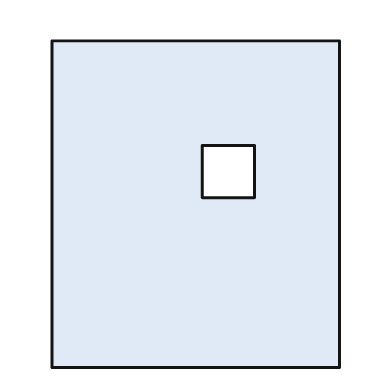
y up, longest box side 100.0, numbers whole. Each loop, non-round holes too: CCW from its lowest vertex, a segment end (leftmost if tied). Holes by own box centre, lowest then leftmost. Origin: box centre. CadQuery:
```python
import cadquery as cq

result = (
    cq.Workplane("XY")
    .moveTo(-44.0, -50.0)
    .lineTo(44.0, -50.0)
    .lineTo(44.0, 50.0)
    .lineTo(-44.0, 50.0)
    .close()
    .moveTo(2.0, 2.0)
    .lineTo(18.0, 2.0)
    .lineTo(18.0, 18.0)
    .lineTo(2.0, 18.0)
    .close()
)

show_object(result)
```